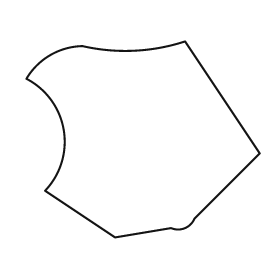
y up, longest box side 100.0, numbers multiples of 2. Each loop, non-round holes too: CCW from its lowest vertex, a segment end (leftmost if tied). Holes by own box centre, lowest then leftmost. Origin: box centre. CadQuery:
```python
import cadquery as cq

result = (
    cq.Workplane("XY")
    .moveTo(-12.0, -42.0)
    .lineTo(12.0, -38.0)
    .threePointArc((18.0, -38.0), (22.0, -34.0))
    .lineTo(50.0, -6.0)
    .lineTo(18.0, 42.0)
    .threePointArc((-4.0, 38.0), (-26.0, 40.0))
    .threePointArc((-40.0, 36.0), (-50.0, 26.0))
    .threePointArc((-34.0, 4.0), (-42.0, -22.0))
    .close()
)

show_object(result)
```